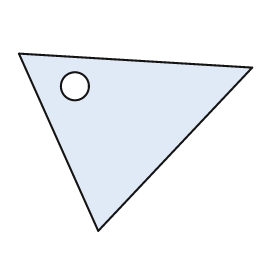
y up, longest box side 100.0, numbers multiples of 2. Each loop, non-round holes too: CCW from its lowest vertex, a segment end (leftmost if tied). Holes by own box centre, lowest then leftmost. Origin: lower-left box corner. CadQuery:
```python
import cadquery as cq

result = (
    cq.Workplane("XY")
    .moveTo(34.0, 0.0)
    .lineTo(100.0, 70.0)
    .lineTo(0.0, 76.0)
    .close()
    .moveTo(24.0, 62.0)
    .circle(6.0)
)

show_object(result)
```